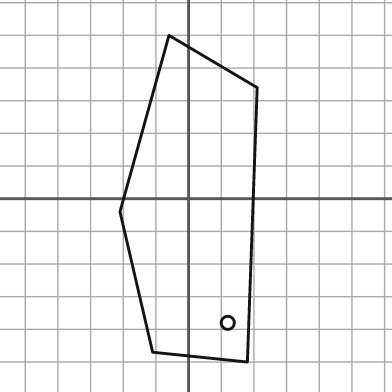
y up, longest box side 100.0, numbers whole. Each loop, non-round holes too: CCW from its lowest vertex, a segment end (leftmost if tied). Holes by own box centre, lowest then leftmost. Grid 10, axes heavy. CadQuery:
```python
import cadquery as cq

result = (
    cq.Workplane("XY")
    .moveTo(18.0, -50.0)
    .lineTo(21.0, 34.0)
    .lineTo(-6.0, 50.0)
    .lineTo(-21.0, -4.0)
    .lineTo(-11.0, -47.0)
    .close()
    .moveTo(12.0, -38.0)
    .circle(2.0)
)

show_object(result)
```